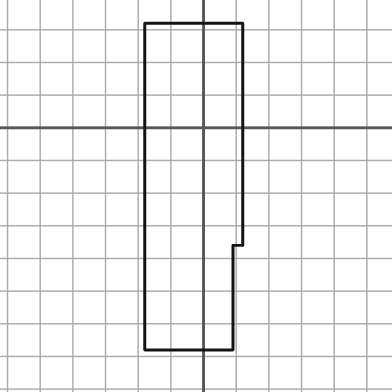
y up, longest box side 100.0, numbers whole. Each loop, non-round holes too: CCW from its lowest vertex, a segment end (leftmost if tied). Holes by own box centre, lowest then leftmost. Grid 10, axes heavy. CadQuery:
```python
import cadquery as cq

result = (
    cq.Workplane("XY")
    .moveTo(-18.0, -68.0)
    .lineTo(9.0, -68.0)
    .lineTo(9.0, -36.0)
    .lineTo(12.0, -36.0)
    .lineTo(12.0, 32.0)
    .lineTo(-18.0, 32.0)
    .close()
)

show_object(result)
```